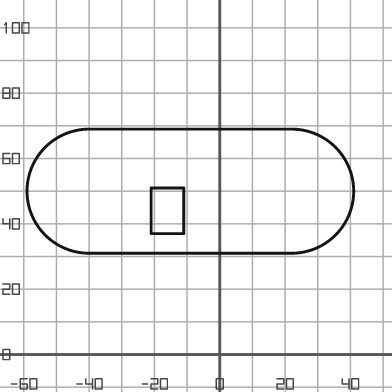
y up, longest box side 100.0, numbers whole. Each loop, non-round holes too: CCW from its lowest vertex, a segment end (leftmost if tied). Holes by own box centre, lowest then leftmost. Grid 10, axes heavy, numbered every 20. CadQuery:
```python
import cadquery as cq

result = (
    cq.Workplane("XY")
    .moveTo(-40.0, 31.0)
    .lineTo(22.0, 31.0)
    .threePointArc((41.0, 50.0), (22.0, 69.0))
    .lineTo(-40.0, 69.0)
    .threePointArc((-59.0, 50.0), (-40.0, 31.0))
    .close()
    .moveTo(-21.0, 37.0)
    .lineTo(-11.0, 37.0)
    .lineTo(-11.0, 51.0)
    .lineTo(-21.0, 51.0)
    .close()
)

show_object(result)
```